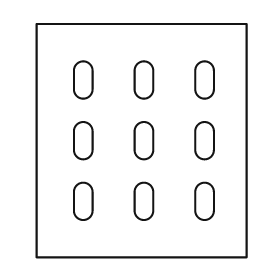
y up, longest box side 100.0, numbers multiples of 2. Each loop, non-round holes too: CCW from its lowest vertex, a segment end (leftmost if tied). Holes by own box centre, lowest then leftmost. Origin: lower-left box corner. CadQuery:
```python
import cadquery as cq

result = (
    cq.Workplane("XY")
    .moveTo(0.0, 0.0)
    .lineTo(90.0, 0.0)
    .lineTo(90.0, 100.0)
    .lineTo(0.0, 100.0)
    .close()
    .moveTo(16.0, 20.0)
    .threePointArc((20.0, 16.0), (24.0, 20.0))
    .lineTo(24.0, 28.0)
    .threePointArc((20.0, 32.0), (16.0, 28.0))
    .close()
    .moveTo(42.0, 20.0)
    .threePointArc((46.0, 16.0), (50.0, 20.0))
    .lineTo(50.0, 28.0)
    .threePointArc((46.0, 32.0), (42.0, 28.0))
    .close()
    .moveTo(68.0, 20.0)
    .threePointArc((72.0, 16.0), (76.0, 20.0))
    .lineTo(76.0, 28.0)
    .threePointArc((72.0, 32.0), (68.0, 28.0))
    .close()
    .moveTo(16.0, 46.0)
    .threePointArc((20.0, 42.0), (24.0, 46.0))
    .lineTo(24.0, 54.0)
    .threePointArc((20.0, 58.0), (16.0, 54.0))
    .close()
    .moveTo(42.0, 46.0)
    .threePointArc((46.0, 42.0), (50.0, 46.0))
    .lineTo(50.0, 54.0)
    .threePointArc((46.0, 58.0), (42.0, 54.0))
    .close()
    .moveTo(68.0, 46.0)
    .threePointArc((72.0, 42.0), (76.0, 46.0))
    .lineTo(76.0, 54.0)
    .threePointArc((72.0, 58.0), (68.0, 54.0))
    .close()
    .moveTo(16.0, 72.0)
    .threePointArc((20.0, 68.0), (24.0, 72.0))
    .lineTo(24.0, 80.0)
    .threePointArc((20.0, 84.0), (16.0, 80.0))
    .close()
    .moveTo(42.0, 72.0)
    .threePointArc((46.0, 68.0), (50.0, 72.0))
    .lineTo(50.0, 80.0)
    .threePointArc((46.0, 84.0), (42.0, 80.0))
    .close()
    .moveTo(68.0, 72.0)
    .threePointArc((72.0, 68.0), (76.0, 72.0))
    .lineTo(76.0, 80.0)
    .threePointArc((72.0, 84.0), (68.0, 80.0))
    .close()
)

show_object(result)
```